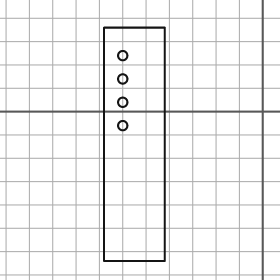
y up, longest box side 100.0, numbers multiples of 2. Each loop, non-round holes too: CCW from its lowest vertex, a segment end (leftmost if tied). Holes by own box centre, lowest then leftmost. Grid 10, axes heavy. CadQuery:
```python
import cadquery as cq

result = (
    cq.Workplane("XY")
    .moveTo(-68.0, -64.0)
    .lineTo(-42.0, -64.0)
    .lineTo(-42.0, 36.0)
    .lineTo(-68.0, 36.0)
    .close()
    .moveTo(-60.0, -6.0)
    .circle(2.0)
    .moveTo(-60.0, 4.0)
    .circle(2.0)
    .moveTo(-60.0, 14.0)
    .circle(2.0)
    .moveTo(-60.0, 24.0)
    .circle(2.0)
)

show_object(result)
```